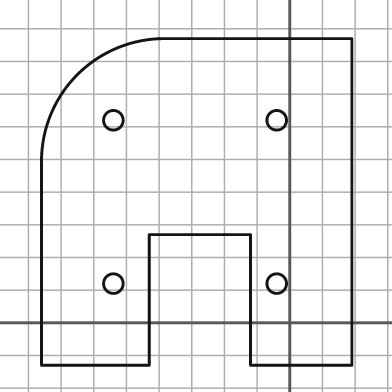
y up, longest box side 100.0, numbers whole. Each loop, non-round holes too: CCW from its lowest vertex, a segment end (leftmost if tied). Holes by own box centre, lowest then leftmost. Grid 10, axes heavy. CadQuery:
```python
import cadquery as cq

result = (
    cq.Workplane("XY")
    .moveTo(-76.0, -13.0)
    .lineTo(-43.0, -13.0)
    .lineTo(-43.0, 27.0)
    .lineTo(-12.0, 27.0)
    .lineTo(-12.0, -13.0)
    .lineTo(19.0, -13.0)
    .lineTo(19.0, 87.0)
    .lineTo(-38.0, 87.0)
    .threePointArc((-65.0, 76.0), (-76.0, 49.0))
    .close()
    .moveTo(-54.0, 12.0)
    .circle(3.0)
    .moveTo(-4.0, 12.0)
    .circle(3.0)
    .moveTo(-54.0, 62.0)
    .circle(3.0)
    .moveTo(-4.0, 62.0)
    .circle(3.0)
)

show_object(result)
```